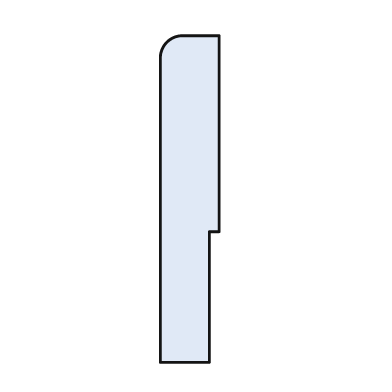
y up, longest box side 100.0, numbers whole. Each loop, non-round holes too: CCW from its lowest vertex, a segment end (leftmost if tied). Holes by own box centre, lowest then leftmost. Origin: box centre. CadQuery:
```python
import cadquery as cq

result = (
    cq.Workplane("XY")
    .moveTo(-9.0, -50.0)
    .lineTo(6.0, -50.0)
    .lineTo(6.0, -10.0)
    .lineTo(9.0, -10.0)
    .lineTo(9.0, 50.0)
    .lineTo(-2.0, 50.0)
    .threePointArc((-7.0, 48.0), (-9.0, 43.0))
    .close()
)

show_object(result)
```